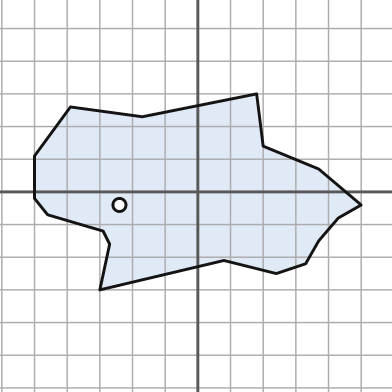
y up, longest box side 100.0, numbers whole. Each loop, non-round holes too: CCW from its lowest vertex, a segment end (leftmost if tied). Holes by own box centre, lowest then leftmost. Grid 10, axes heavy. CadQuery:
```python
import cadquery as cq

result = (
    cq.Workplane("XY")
    .moveTo(-30.0, -30.0)
    .lineTo(8.0, -21.0)
    .lineTo(24.0, -25.0)
    .lineTo(33.0, -22.0)
    .lineTo(37.0, -15.0)
    .lineTo(43.0, -8.0)
    .lineTo(50.0, -4.0)
    .lineTo(37.0, 7.0)
    .lineTo(20.0, 14.0)
    .lineTo(18.0, 30.0)
    .lineTo(-17.0, 23.0)
    .lineTo(-39.0, 26.0)
    .lineTo(-50.0, 11.0)
    .lineTo(-50.0, -2.0)
    .lineTo(-46.0, -7.0)
    .lineTo(-29.0, -12.0)
    .lineTo(-27.0, -16.0)
    .close()
    .moveTo(-24.0, -4.0)
    .circle(2.0)
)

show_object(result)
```